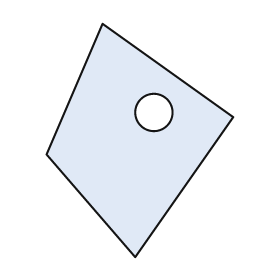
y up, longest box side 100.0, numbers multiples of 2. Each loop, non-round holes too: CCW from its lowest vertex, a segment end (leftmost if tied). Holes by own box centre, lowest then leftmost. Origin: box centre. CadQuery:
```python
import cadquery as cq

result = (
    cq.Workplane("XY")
    .moveTo(-2.0, -50.0)
    .lineTo(40.0, 10.0)
    .lineTo(-16.0, 50.0)
    .lineTo(-40.0, -6.0)
    .close()
    .moveTo(6.0, 12.0)
    .circle(8.0)
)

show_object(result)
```